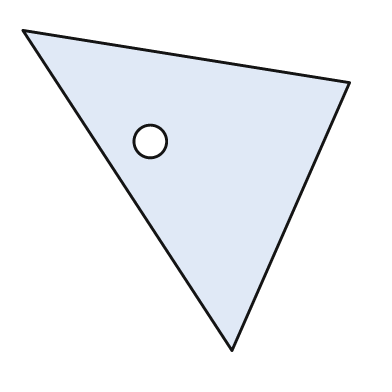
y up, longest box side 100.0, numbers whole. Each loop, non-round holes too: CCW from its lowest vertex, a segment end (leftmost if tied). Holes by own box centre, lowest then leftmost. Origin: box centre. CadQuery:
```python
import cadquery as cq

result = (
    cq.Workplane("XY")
    .moveTo(14.0, -49.0)
    .lineTo(50.0, 33.0)
    .lineTo(-50.0, 49.0)
    .close()
    .moveTo(-11.0, 15.0)
    .circle(5.0)
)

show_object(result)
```